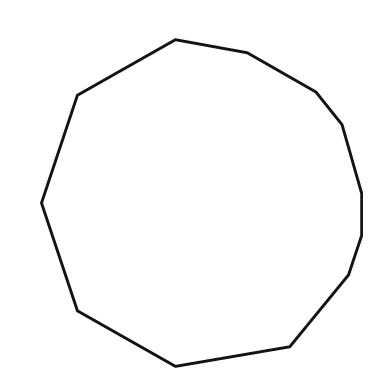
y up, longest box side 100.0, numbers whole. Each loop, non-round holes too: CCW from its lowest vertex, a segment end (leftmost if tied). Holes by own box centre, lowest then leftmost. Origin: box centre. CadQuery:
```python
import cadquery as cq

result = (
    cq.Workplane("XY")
    .moveTo(-8.0, -50.0)
    .lineTo(27.0, -44.0)
    .lineTo(45.0, -22.0)
    .lineTo(49.0, -10.0)
    .lineTo(49.0, 3.0)
    .lineTo(43.0, 24.0)
    .lineTo(35.0, 34.0)
    .lineTo(14.0, 46.0)
    .lineTo(-8.0, 50.0)
    .lineTo(-38.0, 33.0)
    .lineTo(-49.0, 0.0)
    .lineTo(-38.0, -33.0)
    .close()
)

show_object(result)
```